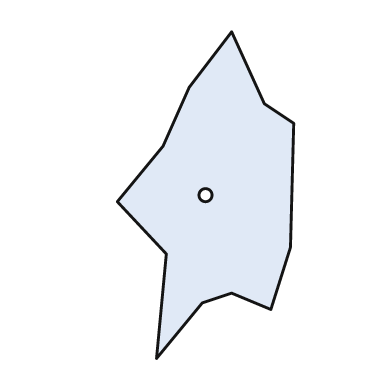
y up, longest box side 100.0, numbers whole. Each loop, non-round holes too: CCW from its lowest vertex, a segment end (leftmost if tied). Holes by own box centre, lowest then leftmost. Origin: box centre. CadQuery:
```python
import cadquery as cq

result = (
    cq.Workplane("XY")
    .moveTo(-15.0, -50.0)
    .lineTo(-1.0, -33.0)
    .lineTo(8.0, -30.0)
    .lineTo(20.0, -35.0)
    .lineTo(26.0, -16.0)
    .lineTo(27.0, 22.0)
    .lineTo(18.0, 28.0)
    .lineTo(8.0, 50.0)
    .lineTo(-5.0, 33.0)
    .lineTo(-13.0, 15.0)
    .lineTo(-27.0, -2.0)
    .lineTo(-12.0, -18.0)
    .close()
    .moveTo(0.0, 0.0)
    .circle(2.0)
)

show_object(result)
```